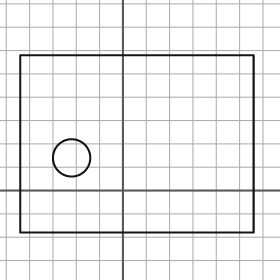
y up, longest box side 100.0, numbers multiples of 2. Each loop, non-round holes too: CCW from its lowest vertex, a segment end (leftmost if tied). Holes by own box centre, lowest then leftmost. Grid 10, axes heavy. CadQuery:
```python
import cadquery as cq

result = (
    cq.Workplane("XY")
    .moveTo(-44.0, -18.0)
    .lineTo(56.0, -18.0)
    .lineTo(56.0, 58.0)
    .lineTo(-44.0, 58.0)
    .close()
    .moveTo(-22.0, 14.0)
    .circle(8.0)
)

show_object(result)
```